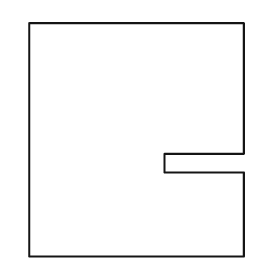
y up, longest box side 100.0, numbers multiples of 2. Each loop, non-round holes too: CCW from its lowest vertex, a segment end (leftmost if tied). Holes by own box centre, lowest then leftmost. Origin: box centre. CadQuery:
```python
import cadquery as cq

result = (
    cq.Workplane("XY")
    .moveTo(-46.0, -50.0)
    .lineTo(46.0, -50.0)
    .lineTo(46.0, -14.0)
    .lineTo(12.0, -14.0)
    .lineTo(12.0, -6.0)
    .lineTo(46.0, -6.0)
    .lineTo(46.0, 50.0)
    .lineTo(-46.0, 50.0)
    .close()
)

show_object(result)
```